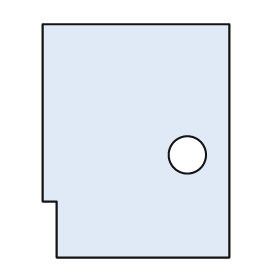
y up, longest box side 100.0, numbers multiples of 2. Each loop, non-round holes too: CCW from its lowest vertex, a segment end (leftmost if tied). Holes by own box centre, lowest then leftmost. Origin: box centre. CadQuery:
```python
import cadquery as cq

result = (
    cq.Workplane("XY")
    .moveTo(-34.0, -50.0)
    .lineTo(40.0, -50.0)
    .lineTo(40.0, 50.0)
    .lineTo(-40.0, 50.0)
    .lineTo(-40.0, -26.0)
    .lineTo(-34.0, -26.0)
    .close()
    .moveTo(22.0, -6.0)
    .circle(8.0)
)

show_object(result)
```